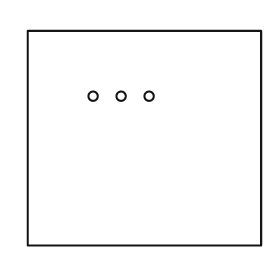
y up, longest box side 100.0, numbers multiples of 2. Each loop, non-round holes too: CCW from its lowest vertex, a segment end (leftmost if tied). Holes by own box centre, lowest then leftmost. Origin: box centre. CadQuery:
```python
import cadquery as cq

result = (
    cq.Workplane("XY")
    .moveTo(-50.0, -46.0)
    .lineTo(50.0, -46.0)
    .lineTo(50.0, 46.0)
    .lineTo(-50.0, 46.0)
    .close()
    .moveTo(-22.0, 18.0)
    .circle(2.0)
    .moveTo(-10.0, 18.0)
    .circle(2.0)
    .moveTo(2.0, 18.0)
    .circle(2.0)
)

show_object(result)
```